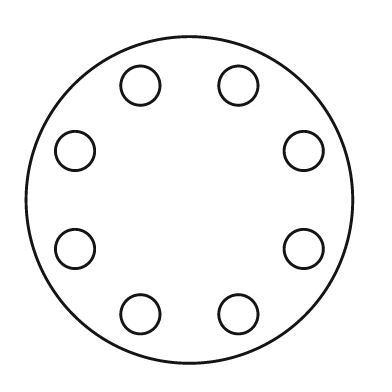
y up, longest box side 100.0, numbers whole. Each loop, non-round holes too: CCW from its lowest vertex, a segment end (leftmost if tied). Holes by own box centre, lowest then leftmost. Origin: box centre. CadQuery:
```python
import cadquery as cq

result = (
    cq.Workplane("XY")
    .moveTo(0.0, 0.0)
    .circle(50.0)
    .moveTo(-15.0, -35.0)
    .circle(6.0)
    .moveTo(15.0, -35.0)
    .circle(6.0)
    .moveTo(-35.0, -15.0)
    .circle(6.0)
    .moveTo(35.0, -15.0)
    .circle(6.0)
    .moveTo(-35.0, 15.0)
    .circle(6.0)
    .moveTo(35.0, 15.0)
    .circle(6.0)
    .moveTo(-15.0, 35.0)
    .circle(6.0)
    .moveTo(15.0, 35.0)
    .circle(6.0)
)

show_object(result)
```